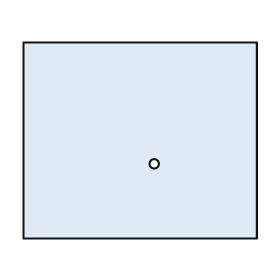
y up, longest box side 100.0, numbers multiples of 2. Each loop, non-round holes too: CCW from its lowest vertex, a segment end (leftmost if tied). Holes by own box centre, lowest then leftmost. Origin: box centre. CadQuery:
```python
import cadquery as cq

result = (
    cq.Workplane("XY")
    .moveTo(-50.0, -42.0)
    .lineTo(50.0, -42.0)
    .lineTo(50.0, 42.0)
    .lineTo(-50.0, 42.0)
    .close()
    .moveTo(6.0, -10.0)
    .circle(2.0)
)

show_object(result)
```